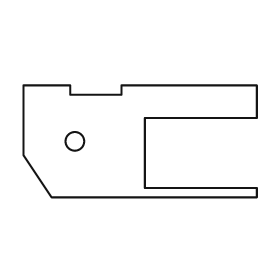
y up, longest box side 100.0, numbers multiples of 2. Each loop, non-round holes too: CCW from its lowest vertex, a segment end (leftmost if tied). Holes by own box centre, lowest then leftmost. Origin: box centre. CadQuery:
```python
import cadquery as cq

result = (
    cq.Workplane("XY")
    .moveTo(-38.0, -24.0)
    .lineTo(50.0, -24.0)
    .lineTo(50.0, -20.0)
    .lineTo(2.0, -20.0)
    .lineTo(2.0, 10.0)
    .lineTo(50.0, 10.0)
    .lineTo(50.0, 24.0)
    .lineTo(-8.0, 24.0)
    .lineTo(-8.0, 20.0)
    .lineTo(-30.0, 20.0)
    .lineTo(-30.0, 24.0)
    .lineTo(-50.0, 24.0)
    .lineTo(-50.0, -6.0)
    .close()
    .moveTo(-28.0, 0.0)
    .circle(4.0)
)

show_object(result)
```